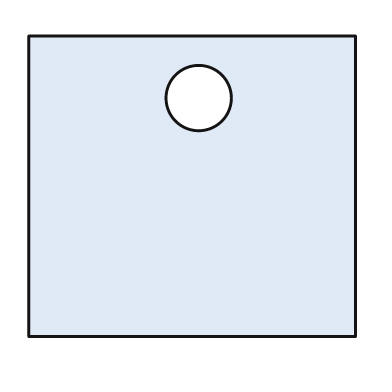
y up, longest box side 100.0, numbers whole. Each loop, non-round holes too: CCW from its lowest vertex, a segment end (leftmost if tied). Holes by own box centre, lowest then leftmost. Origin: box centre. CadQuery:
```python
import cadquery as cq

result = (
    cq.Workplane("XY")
    .moveTo(-50.0, -46.0)
    .lineTo(50.0, -46.0)
    .lineTo(50.0, 46.0)
    .lineTo(-50.0, 46.0)
    .close()
    .moveTo(2.0, 27.0)
    .circle(10.0)
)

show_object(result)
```